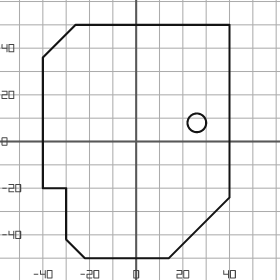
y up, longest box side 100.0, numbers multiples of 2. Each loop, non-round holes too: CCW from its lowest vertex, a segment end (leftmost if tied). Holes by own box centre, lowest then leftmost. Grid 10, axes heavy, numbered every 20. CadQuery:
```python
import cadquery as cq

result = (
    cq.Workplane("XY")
    .moveTo(-22.0, -50.0)
    .lineTo(14.0, -50.0)
    .lineTo(40.0, -24.0)
    .lineTo(40.0, 50.0)
    .lineTo(-26.0, 50.0)
    .lineTo(-40.0, 36.0)
    .lineTo(-40.0, -20.0)
    .lineTo(-30.0, -20.0)
    .lineTo(-30.0, -42.0)
    .close()
    .moveTo(26.0, 8.0)
    .circle(4.0)
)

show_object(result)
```